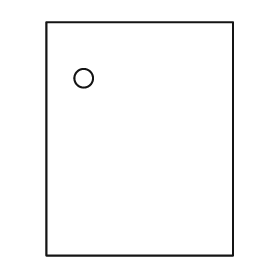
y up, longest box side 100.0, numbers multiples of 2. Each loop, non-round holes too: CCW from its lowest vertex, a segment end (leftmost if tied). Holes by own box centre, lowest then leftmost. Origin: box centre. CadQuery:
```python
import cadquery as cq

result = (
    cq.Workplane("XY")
    .moveTo(-40.0, -50.0)
    .lineTo(40.0, -50.0)
    .lineTo(40.0, 50.0)
    .lineTo(-40.0, 50.0)
    .close()
    .moveTo(-24.0, 26.0)
    .circle(4.0)
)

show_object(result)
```